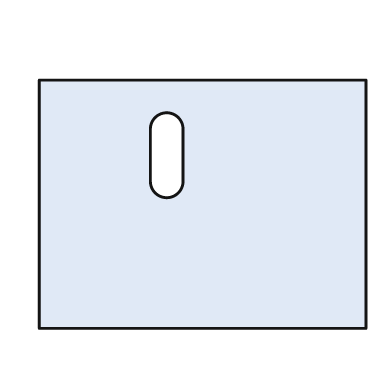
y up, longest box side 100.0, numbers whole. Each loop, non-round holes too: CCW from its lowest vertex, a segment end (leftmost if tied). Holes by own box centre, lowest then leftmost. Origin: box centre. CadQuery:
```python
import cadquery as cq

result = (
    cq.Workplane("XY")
    .moveTo(-50.0, -38.0)
    .lineTo(50.0, -38.0)
    .lineTo(50.0, 38.0)
    .lineTo(-50.0, 38.0)
    .close()
    .moveTo(-16.0, 7.0)
    .threePointArc((-11.0, 2.0), (-6.0, 7.0))
    .lineTo(-6.0, 23.0)
    .threePointArc((-11.0, 28.0), (-16.0, 23.0))
    .close()
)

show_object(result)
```